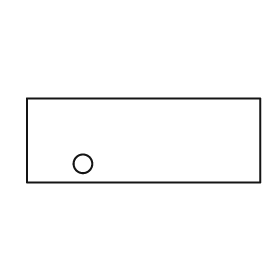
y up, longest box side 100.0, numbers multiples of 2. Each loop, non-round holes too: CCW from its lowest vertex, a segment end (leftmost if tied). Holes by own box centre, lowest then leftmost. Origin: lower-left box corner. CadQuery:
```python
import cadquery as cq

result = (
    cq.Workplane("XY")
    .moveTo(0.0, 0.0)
    .lineTo(100.0, 0.0)
    .lineTo(100.0, 36.0)
    .lineTo(0.0, 36.0)
    .close()
    .moveTo(24.0, 8.0)
    .circle(4.0)
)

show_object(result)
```